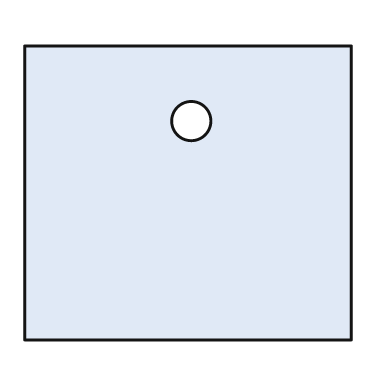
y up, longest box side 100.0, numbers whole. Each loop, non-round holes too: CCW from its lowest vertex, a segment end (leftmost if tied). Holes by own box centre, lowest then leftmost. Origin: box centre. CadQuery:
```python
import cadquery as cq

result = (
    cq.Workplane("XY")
    .moveTo(-50.0, -45.0)
    .lineTo(50.0, -45.0)
    .lineTo(50.0, 45.0)
    .lineTo(-50.0, 45.0)
    .close()
    .moveTo(1.0, 22.0)
    .circle(6.0)
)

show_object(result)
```